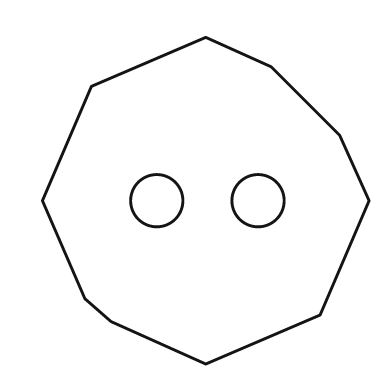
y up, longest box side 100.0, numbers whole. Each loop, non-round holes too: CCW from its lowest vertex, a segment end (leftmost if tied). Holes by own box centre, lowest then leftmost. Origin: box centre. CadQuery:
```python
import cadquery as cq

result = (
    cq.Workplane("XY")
    .moveTo(0.0, -50.0)
    .lineTo(35.0, -35.0)
    .lineTo(50.0, 0.0)
    .lineTo(41.0, 20.0)
    .lineTo(20.0, 41.0)
    .lineTo(0.0, 50.0)
    .lineTo(-35.0, 35.0)
    .lineTo(-50.0, 0.0)
    .lineTo(-37.0, -30.0)
    .lineTo(-29.0, -37.0)
    .close()
    .moveTo(-15.0, 0.0)
    .circle(8.0)
    .moveTo(16.0, 0.0)
    .circle(8.0)
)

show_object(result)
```